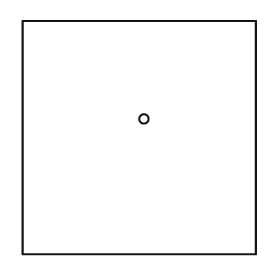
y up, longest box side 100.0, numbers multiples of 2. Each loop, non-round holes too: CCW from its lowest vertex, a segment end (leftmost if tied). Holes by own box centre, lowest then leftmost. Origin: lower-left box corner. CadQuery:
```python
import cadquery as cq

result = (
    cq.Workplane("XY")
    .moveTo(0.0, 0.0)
    .lineTo(100.0, 0.0)
    .lineTo(100.0, 100.0)
    .lineTo(0.0, 100.0)
    .close()
    .moveTo(52.0, 58.0)
    .circle(2.0)
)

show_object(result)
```